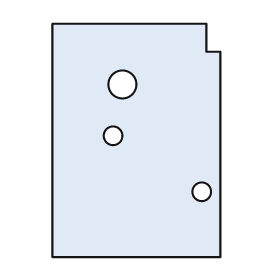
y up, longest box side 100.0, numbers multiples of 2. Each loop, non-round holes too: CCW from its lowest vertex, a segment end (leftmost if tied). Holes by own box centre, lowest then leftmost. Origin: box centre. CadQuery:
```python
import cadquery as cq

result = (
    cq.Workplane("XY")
    .moveTo(-36.0, -50.0)
    .lineTo(36.0, -50.0)
    .lineTo(36.0, 38.0)
    .lineTo(30.0, 38.0)
    .lineTo(30.0, 50.0)
    .lineTo(-36.0, 50.0)
    .close()
    .moveTo(28.0, -22.0)
    .circle(4.0)
    .moveTo(-10.0, 2.0)
    .circle(4.0)
    .moveTo(-6.0, 24.0)
    .circle(6.0)
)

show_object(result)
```